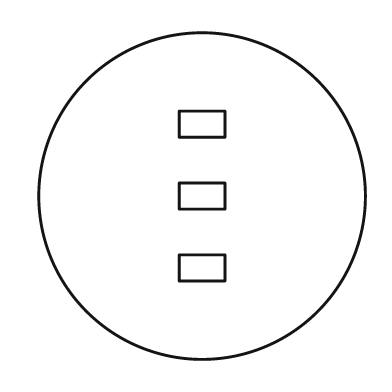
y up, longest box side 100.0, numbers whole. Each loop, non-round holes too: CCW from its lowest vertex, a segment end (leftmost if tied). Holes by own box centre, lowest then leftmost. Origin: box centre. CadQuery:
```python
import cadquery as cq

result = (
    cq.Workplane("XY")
    .moveTo(0.0, 0.0)
    .circle(50.0)
    .moveTo(-7.0, -26.0)
    .lineTo(7.0, -26.0)
    .lineTo(7.0, -18.0)
    .lineTo(-7.0, -18.0)
    .close()
    .moveTo(-7.0, -4.0)
    .lineTo(7.0, -4.0)
    .lineTo(7.0, 4.0)
    .lineTo(-7.0, 4.0)
    .close()
    .moveTo(-7.0, 18.0)
    .lineTo(7.0, 18.0)
    .lineTo(7.0, 26.0)
    .lineTo(-7.0, 26.0)
    .close()
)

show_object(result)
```